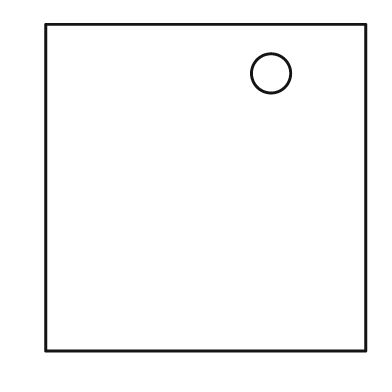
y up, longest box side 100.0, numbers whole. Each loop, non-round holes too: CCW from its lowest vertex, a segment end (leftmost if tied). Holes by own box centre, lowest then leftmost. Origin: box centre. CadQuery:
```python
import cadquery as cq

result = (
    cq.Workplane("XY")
    .moveTo(-49.0, -50.0)
    .lineTo(49.0, -50.0)
    .lineTo(49.0, 50.0)
    .lineTo(-49.0, 50.0)
    .close()
    .moveTo(20.0, 35.0)
    .circle(6.0)
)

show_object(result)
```